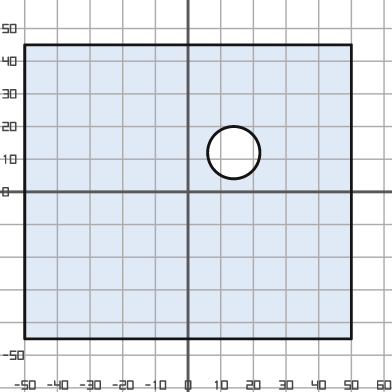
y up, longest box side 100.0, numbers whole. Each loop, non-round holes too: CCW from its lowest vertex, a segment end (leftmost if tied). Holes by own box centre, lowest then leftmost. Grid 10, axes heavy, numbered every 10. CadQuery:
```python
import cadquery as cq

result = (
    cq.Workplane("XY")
    .moveTo(-50.0, -45.0)
    .lineTo(50.0, -45.0)
    .lineTo(50.0, 45.0)
    .lineTo(-50.0, 45.0)
    .close()
    .moveTo(14.0, 12.0)
    .circle(8.0)
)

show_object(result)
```